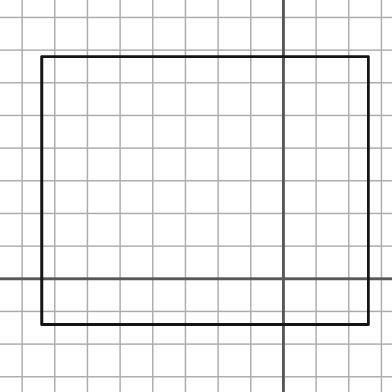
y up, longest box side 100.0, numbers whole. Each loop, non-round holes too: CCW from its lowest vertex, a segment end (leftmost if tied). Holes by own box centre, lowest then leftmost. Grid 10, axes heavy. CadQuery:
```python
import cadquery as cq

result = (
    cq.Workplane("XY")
    .moveTo(-74.0, -14.0)
    .lineTo(26.0, -14.0)
    .lineTo(26.0, 68.0)
    .lineTo(-74.0, 68.0)
    .close()
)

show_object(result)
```